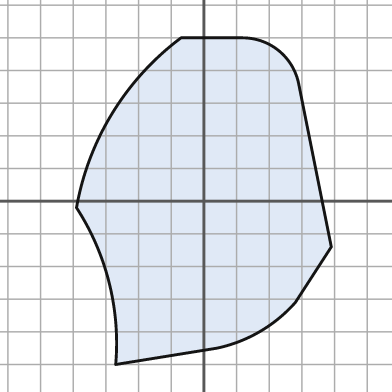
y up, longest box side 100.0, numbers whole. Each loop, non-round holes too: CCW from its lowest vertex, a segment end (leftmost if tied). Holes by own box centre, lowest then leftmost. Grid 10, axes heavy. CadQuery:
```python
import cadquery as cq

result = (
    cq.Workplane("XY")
    .moveTo(-27.0, -50.0)
    .lineTo(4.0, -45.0)
    .threePointArc((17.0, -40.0), (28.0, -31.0))
    .lineTo(39.0, -14.0)
    .lineTo(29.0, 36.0)
    .threePointArc((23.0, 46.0), (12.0, 50.0))
    .lineTo(-7.0, 50.0)
    .threePointArc((-28.0, 27.0), (-39.0, -2.0))
    .threePointArc((-29.0, -25.0), (-27.0, -50.0))
    .close()
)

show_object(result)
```